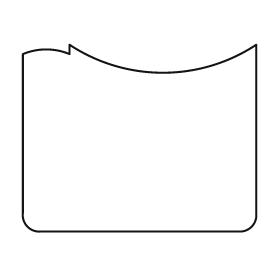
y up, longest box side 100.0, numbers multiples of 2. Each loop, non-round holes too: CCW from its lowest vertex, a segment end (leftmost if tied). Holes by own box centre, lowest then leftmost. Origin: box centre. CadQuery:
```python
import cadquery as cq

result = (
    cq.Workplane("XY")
    .moveTo(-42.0, -40.0)
    .lineTo(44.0, -40.0)
    .threePointArc((48.0, -38.0), (50.0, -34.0))
    .lineTo(50.0, 40.0)
    .threePointArc((10.0, 28.0), (-30.0, 40.0))
    .lineTo(-30.0, 36.0)
    .threePointArc((-40.0, 38.0), (-50.0, 36.0))
    .lineTo(-50.0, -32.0)
    .threePointArc((-48.0, -38.0), (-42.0, -40.0))
    .close()
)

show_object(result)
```